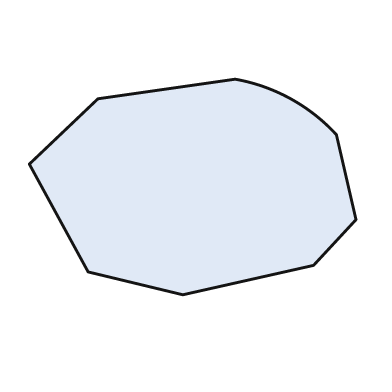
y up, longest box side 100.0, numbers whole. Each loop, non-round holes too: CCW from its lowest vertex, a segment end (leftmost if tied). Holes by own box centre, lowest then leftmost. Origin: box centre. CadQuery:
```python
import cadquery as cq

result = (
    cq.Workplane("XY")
    .moveTo(-3.0, -33.0)
    .lineTo(37.0, -24.0)
    .lineTo(50.0, -10.0)
    .lineTo(44.0, 16.0)
    .threePointArc((30.0, 27.0), (13.0, 33.0))
    .lineTo(-29.0, 27.0)
    .lineTo(-50.0, 7.0)
    .lineTo(-32.0, -26.0)
    .close()
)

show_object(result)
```